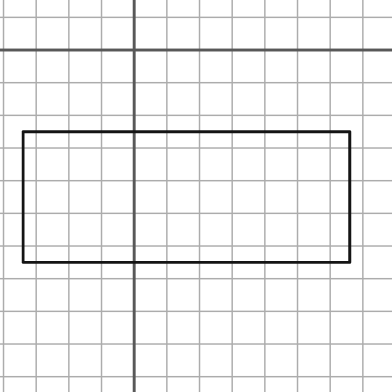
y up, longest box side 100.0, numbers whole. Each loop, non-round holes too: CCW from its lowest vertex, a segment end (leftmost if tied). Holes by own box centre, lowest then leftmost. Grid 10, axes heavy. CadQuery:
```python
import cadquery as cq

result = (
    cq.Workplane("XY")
    .moveTo(-34.0, -65.0)
    .lineTo(66.0, -65.0)
    .lineTo(66.0, -25.0)
    .lineTo(-34.0, -25.0)
    .close()
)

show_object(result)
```